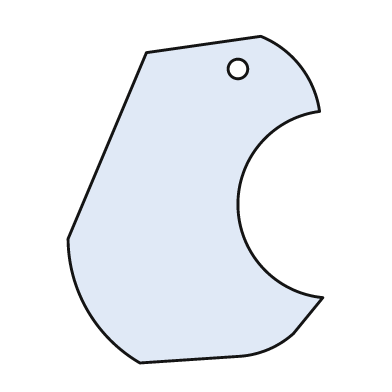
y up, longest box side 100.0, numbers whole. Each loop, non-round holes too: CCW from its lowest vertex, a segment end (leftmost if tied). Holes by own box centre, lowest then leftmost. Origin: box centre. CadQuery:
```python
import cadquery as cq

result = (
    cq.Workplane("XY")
    .moveTo(-17.0, -50.0)
    .lineTo(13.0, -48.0)
    .threePointArc((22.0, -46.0), (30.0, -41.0))
    .lineTo(39.0, -30.0)
    .threePointArc((13.0, -2.0), (38.0, 27.0))
    .threePointArc((32.0, 41.0), (20.0, 50.0))
    .lineTo(-15.0, 45.0)
    .lineTo(-39.0, -12.0)
    .threePointArc((-33.0, -34.0), (-17.0, -50.0))
    .close()
    .moveTo(13.0, 40.0)
    .circle(3.0)
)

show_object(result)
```